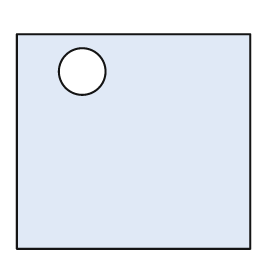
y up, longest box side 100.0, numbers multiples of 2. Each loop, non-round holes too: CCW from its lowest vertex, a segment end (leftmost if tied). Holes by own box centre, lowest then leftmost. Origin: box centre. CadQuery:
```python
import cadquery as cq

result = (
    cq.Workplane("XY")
    .moveTo(-50.0, -46.0)
    .lineTo(50.0, -46.0)
    .lineTo(50.0, 46.0)
    .lineTo(-50.0, 46.0)
    .close()
    .moveTo(-22.0, 30.0)
    .circle(10.0)
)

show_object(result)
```